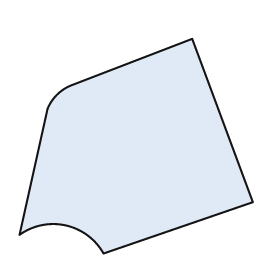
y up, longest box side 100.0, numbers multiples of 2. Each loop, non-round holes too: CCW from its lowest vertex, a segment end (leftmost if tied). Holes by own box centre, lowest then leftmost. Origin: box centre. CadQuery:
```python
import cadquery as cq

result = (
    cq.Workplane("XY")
    .moveTo(-14.0, -46.0)
    .lineTo(50.0, -24.0)
    .lineTo(24.0, 46.0)
    .lineTo(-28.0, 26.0)
    .threePointArc((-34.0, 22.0), (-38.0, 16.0))
    .lineTo(-50.0, -38.0)
    .threePointArc((-30.0, -34.0), (-14.0, -46.0))
    .close()
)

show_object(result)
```